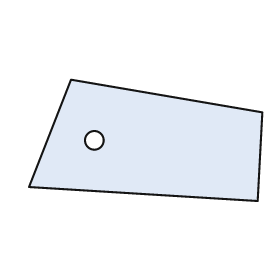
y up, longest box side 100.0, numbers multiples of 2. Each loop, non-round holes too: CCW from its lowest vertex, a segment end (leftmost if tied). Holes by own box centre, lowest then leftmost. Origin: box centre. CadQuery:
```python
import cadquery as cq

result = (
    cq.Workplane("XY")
    .moveTo(48.0, -26.0)
    .lineTo(50.0, 12.0)
    .lineTo(-32.0, 26.0)
    .lineTo(-50.0, -20.0)
    .close()
    .moveTo(-22.0, 0.0)
    .circle(4.0)
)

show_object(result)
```